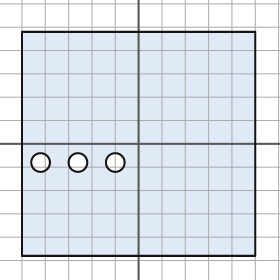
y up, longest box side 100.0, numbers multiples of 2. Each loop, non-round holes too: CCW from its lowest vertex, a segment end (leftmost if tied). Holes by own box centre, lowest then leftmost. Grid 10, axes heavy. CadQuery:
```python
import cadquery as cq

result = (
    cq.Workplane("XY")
    .moveTo(-50.0, -48.0)
    .lineTo(50.0, -48.0)
    .lineTo(50.0, 48.0)
    .lineTo(-50.0, 48.0)
    .close()
    .moveTo(-42.0, -8.0)
    .circle(4.0)
    .moveTo(-26.0, -8.0)
    .circle(4.0)
    .moveTo(-10.0, -8.0)
    .circle(4.0)
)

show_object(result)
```